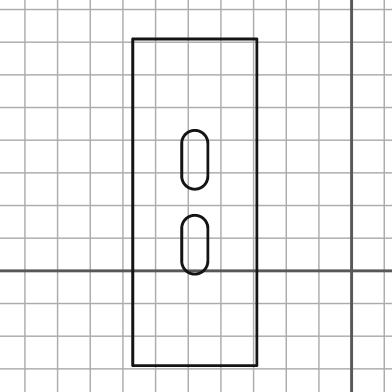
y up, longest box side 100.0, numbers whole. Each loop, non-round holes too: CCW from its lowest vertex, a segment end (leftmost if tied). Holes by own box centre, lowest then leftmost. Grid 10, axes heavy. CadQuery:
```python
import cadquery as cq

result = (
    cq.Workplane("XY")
    .moveTo(-67.0, -29.0)
    .lineTo(-29.0, -29.0)
    .lineTo(-29.0, 71.0)
    .lineTo(-67.0, 71.0)
    .close()
    .moveTo(-52.0, 3.0)
    .threePointArc((-48.0, -1.0), (-44.0, 3.0))
    .lineTo(-44.0, 13.0)
    .threePointArc((-48.0, 17.0), (-52.0, 13.0))
    .close()
    .moveTo(-52.0, 29.0)
    .threePointArc((-48.0, 25.0), (-44.0, 29.0))
    .lineTo(-44.0, 39.0)
    .threePointArc((-48.0, 43.0), (-52.0, 39.0))
    .close()
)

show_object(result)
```